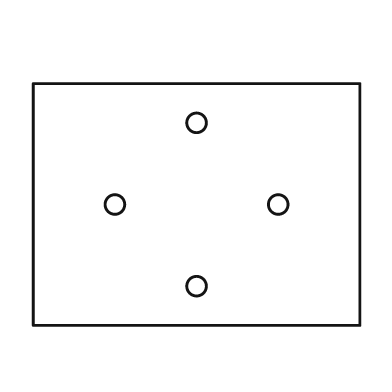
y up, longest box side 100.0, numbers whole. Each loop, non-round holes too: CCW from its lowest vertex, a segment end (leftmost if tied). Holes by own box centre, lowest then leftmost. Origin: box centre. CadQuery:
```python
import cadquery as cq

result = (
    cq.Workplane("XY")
    .moveTo(-50.0, -37.0)
    .lineTo(50.0, -37.0)
    .lineTo(50.0, 37.0)
    .lineTo(-50.0, 37.0)
    .close()
    .moveTo(0.0, -25.0)
    .circle(3.0)
    .moveTo(-25.0, 0.0)
    .circle(3.0)
    .moveTo(25.0, 0.0)
    .circle(3.0)
    .moveTo(0.0, 25.0)
    .circle(3.0)
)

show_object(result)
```